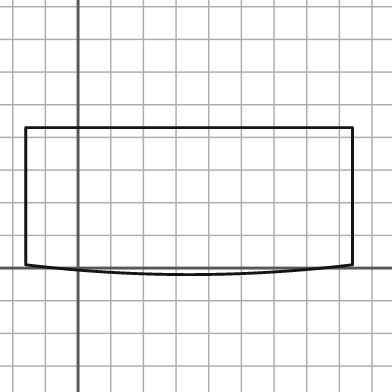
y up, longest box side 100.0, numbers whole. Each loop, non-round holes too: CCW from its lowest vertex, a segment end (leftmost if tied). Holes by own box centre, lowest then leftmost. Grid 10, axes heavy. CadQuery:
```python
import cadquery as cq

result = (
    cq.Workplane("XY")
    .moveTo(-16.0, 1.0)
    .threePointArc((34.0, -2.0), (84.0, 1.0))
    .lineTo(84.0, 43.0)
    .lineTo(-16.0, 43.0)
    .close()
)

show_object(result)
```